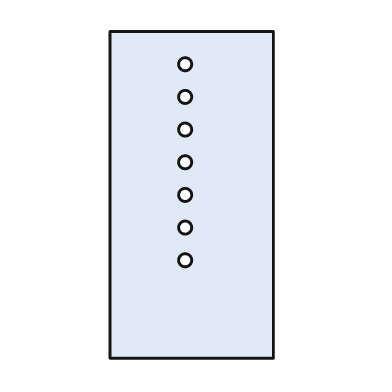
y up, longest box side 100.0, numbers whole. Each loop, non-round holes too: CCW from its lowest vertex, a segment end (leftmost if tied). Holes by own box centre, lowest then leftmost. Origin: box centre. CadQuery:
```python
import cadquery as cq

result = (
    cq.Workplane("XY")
    .moveTo(-25.0, -50.0)
    .lineTo(25.0, -50.0)
    .lineTo(25.0, 50.0)
    .lineTo(-25.0, 50.0)
    .close()
    .moveTo(-2.0, -20.0)
    .circle(2.0)
    .moveTo(-2.0, -10.0)
    .circle(2.0)
    .moveTo(-2.0, 0.0)
    .circle(2.0)
    .moveTo(-2.0, 10.0)
    .circle(2.0)
    .moveTo(-2.0, 20.0)
    .circle(2.0)
    .moveTo(-2.0, 30.0)
    .circle(2.0)
    .moveTo(-2.0, 40.0)
    .circle(2.0)
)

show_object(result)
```